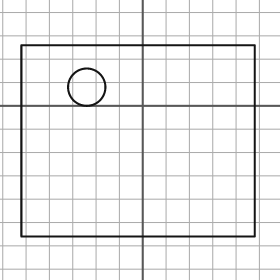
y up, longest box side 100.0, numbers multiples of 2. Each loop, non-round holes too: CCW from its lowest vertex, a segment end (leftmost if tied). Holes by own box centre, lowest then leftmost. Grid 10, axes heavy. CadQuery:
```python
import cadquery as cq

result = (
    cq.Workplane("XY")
    .moveTo(-52.0, -56.0)
    .lineTo(48.0, -56.0)
    .lineTo(48.0, 26.0)
    .lineTo(-52.0, 26.0)
    .close()
    .moveTo(-24.0, 8.0)
    .circle(8.0)
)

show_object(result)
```